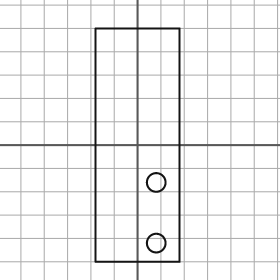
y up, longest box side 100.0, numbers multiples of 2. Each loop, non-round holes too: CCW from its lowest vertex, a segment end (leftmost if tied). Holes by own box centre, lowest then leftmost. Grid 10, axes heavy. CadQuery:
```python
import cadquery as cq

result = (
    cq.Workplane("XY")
    .moveTo(-18.0, -50.0)
    .lineTo(18.0, -50.0)
    .lineTo(18.0, 50.0)
    .lineTo(-18.0, 50.0)
    .close()
    .moveTo(8.0, -42.0)
    .circle(4.0)
    .moveTo(8.0, -16.0)
    .circle(4.0)
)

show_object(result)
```